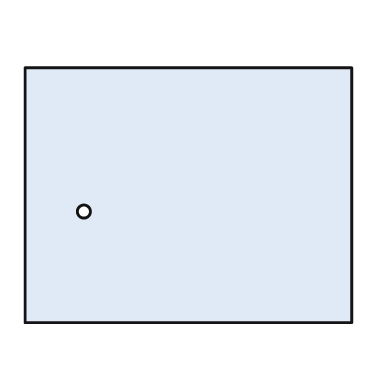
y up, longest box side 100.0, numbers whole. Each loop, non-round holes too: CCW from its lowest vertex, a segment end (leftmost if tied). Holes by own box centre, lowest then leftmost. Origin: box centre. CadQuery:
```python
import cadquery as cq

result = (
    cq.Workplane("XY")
    .moveTo(-50.0, -39.0)
    .lineTo(50.0, -39.0)
    .lineTo(50.0, 39.0)
    .lineTo(-50.0, 39.0)
    .close()
    .moveTo(-32.0, -5.0)
    .circle(2.0)
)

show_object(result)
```